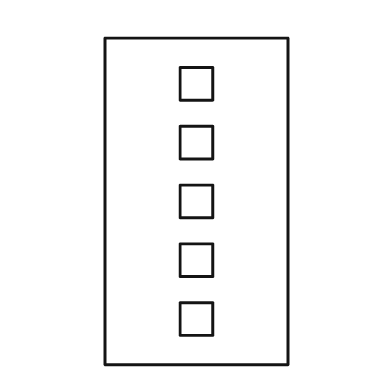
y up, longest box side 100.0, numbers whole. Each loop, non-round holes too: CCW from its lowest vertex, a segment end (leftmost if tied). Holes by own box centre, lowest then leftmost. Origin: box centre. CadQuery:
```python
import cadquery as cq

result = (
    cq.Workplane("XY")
    .moveTo(-28.0, -50.0)
    .lineTo(28.0, -50.0)
    .lineTo(28.0, 50.0)
    .lineTo(-28.0, 50.0)
    .close()
    .moveTo(-5.0, -41.0)
    .lineTo(5.0, -41.0)
    .lineTo(5.0, -31.0)
    .lineTo(-5.0, -31.0)
    .close()
    .moveTo(-5.0, -23.0)
    .lineTo(5.0, -23.0)
    .lineTo(5.0, -13.0)
    .lineTo(-5.0, -13.0)
    .close()
    .moveTo(-5.0, -5.0)
    .lineTo(5.0, -5.0)
    .lineTo(5.0, 5.0)
    .lineTo(-5.0, 5.0)
    .close()
    .moveTo(-5.0, 13.0)
    .lineTo(5.0, 13.0)
    .lineTo(5.0, 23.0)
    .lineTo(-5.0, 23.0)
    .close()
    .moveTo(-5.0, 31.0)
    .lineTo(5.0, 31.0)
    .lineTo(5.0, 41.0)
    .lineTo(-5.0, 41.0)
    .close()
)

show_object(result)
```